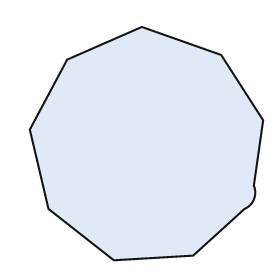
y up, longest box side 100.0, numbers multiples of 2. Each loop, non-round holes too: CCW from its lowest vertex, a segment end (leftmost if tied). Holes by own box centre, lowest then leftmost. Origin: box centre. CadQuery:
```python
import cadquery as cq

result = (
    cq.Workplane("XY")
    .moveTo(-14.0, -50.0)
    .lineTo(20.0, -48.0)
    .lineTo(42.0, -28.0)
    .threePointArc((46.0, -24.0), (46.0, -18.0))
    .lineTo(50.0, 10.0)
    .lineTo(32.0, 38.0)
    .lineTo(-2.0, 50.0)
    .lineTo(-34.0, 36.0)
    .lineTo(-50.0, 6.0)
    .lineTo(-42.0, -28.0)
    .close()
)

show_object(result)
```